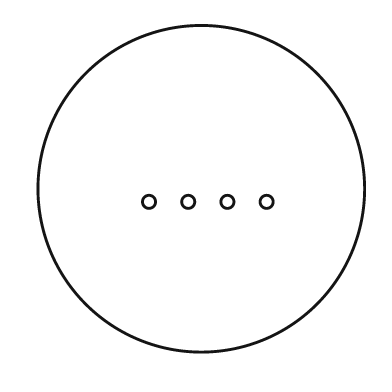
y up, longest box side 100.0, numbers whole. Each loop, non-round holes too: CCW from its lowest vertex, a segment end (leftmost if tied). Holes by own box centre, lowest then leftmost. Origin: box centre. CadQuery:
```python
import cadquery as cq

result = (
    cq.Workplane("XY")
    .moveTo(0.0, 0.0)
    .circle(50.0)
    .moveTo(-16.0, -4.0)
    .circle(2.0)
    .moveTo(-4.0, -4.0)
    .circle(2.0)
    .moveTo(8.0, -4.0)
    .circle(2.0)
    .moveTo(20.0, -4.0)
    .circle(2.0)
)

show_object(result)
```